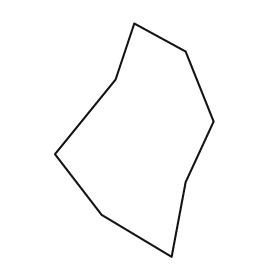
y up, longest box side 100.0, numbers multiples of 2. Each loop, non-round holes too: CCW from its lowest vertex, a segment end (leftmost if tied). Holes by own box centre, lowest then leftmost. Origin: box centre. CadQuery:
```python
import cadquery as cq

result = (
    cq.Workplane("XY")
    .moveTo(16.0, -50.0)
    .lineTo(22.0, -18.0)
    .lineTo(34.0, 8.0)
    .lineTo(22.0, 38.0)
    .lineTo(0.0, 50.0)
    .lineTo(-8.0, 26.0)
    .lineTo(-34.0, -6.0)
    .lineTo(-14.0, -32.0)
    .close()
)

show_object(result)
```